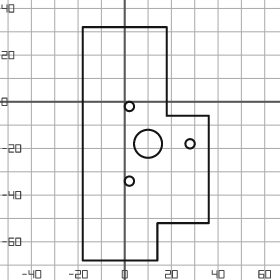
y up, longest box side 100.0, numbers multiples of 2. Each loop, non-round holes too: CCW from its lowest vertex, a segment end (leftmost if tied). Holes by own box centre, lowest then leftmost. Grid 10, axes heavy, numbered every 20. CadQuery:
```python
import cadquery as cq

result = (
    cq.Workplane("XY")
    .moveTo(-18.0, -68.0)
    .lineTo(14.0, -68.0)
    .lineTo(14.0, -52.0)
    .lineTo(36.0, -52.0)
    .lineTo(36.0, -6.0)
    .lineTo(18.0, -6.0)
    .lineTo(18.0, 32.0)
    .lineTo(-18.0, 32.0)
    .close()
    .moveTo(2.0, -34.0)
    .circle(2.0)
    .moveTo(10.0, -18.0)
    .circle(6.0)
    .moveTo(28.0, -18.0)
    .circle(2.0)
    .moveTo(2.0, -2.0)
    .circle(2.0)
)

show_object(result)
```